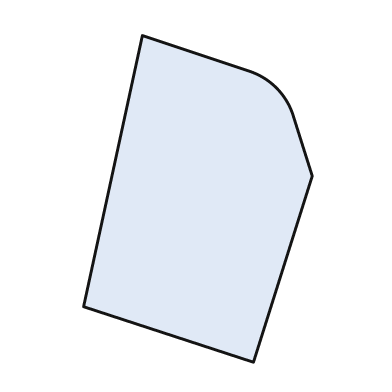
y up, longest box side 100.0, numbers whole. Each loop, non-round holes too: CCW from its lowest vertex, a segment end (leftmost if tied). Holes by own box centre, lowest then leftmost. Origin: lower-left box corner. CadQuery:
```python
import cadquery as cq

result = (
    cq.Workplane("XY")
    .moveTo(52.0, 0.0)
    .lineTo(70.0, 57.0)
    .lineTo(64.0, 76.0)
    .threePointArc((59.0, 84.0), (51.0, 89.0))
    .lineTo(18.0, 100.0)
    .lineTo(0.0, 17.0)
    .close()
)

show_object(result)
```